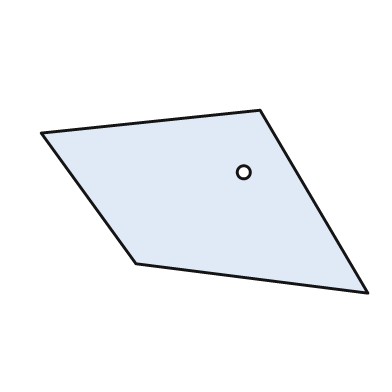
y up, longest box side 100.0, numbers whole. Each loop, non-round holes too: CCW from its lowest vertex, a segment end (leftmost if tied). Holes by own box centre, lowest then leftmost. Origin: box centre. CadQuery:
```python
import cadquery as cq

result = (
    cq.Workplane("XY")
    .moveTo(50.0, -28.0)
    .lineTo(17.0, 28.0)
    .lineTo(-50.0, 21.0)
    .lineTo(-21.0, -19.0)
    .close()
    .moveTo(12.0, 9.0)
    .circle(2.0)
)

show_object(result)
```